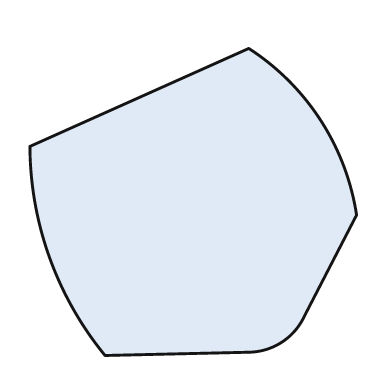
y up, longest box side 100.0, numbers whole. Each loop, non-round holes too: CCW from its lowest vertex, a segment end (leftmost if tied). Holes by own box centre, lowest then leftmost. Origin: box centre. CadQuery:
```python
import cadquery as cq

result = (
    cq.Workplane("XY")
    .moveTo(-27.0, -47.0)
    .lineTo(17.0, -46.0)
    .threePointArc((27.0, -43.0), (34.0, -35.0))
    .lineTo(50.0, -4.0)
    .threePointArc((39.0, 25.0), (17.0, 47.0))
    .lineTo(-50.0, 17.0)
    .threePointArc((-44.0, -17.0), (-27.0, -47.0))
    .close()
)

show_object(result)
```